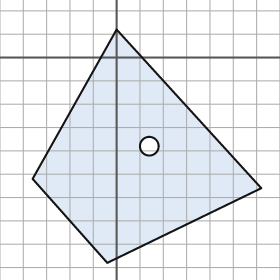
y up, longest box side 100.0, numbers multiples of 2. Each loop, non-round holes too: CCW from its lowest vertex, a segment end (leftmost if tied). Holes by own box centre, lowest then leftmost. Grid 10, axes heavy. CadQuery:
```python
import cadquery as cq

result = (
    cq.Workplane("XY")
    .moveTo(-4.0, -88.0)
    .lineTo(62.0, -56.0)
    .lineTo(0.0, 12.0)
    .lineTo(-36.0, -52.0)
    .close()
    .moveTo(14.0, -38.0)
    .circle(4.0)
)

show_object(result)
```